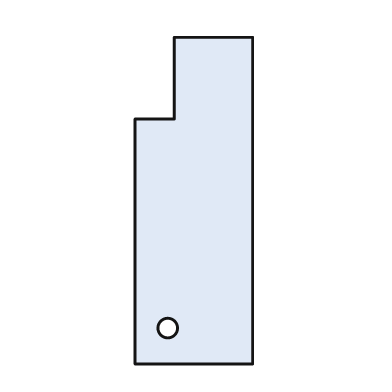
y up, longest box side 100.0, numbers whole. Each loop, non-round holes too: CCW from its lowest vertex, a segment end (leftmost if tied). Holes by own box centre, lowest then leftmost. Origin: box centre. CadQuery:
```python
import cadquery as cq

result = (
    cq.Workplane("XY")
    .moveTo(-18.0, -50.0)
    .lineTo(18.0, -50.0)
    .lineTo(18.0, 50.0)
    .lineTo(-6.0, 50.0)
    .lineTo(-6.0, 25.0)
    .lineTo(-18.0, 25.0)
    .close()
    .moveTo(-8.0, -39.0)
    .circle(3.0)
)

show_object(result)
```